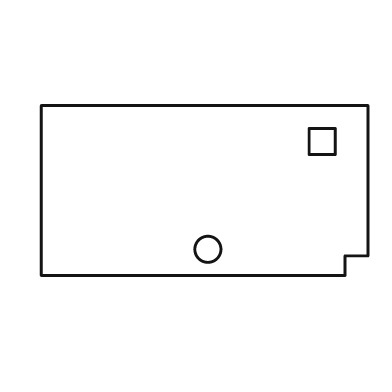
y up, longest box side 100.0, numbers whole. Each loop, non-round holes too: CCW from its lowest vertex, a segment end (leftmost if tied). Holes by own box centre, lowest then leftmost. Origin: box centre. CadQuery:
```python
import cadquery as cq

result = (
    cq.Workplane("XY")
    .moveTo(-50.0, -26.0)
    .lineTo(43.0, -26.0)
    .lineTo(43.0, -20.0)
    .lineTo(50.0, -20.0)
    .lineTo(50.0, 26.0)
    .lineTo(-50.0, 26.0)
    .close()
    .moveTo(1.0, -18.0)
    .circle(4.0)
    .moveTo(32.0, 11.0)
    .lineTo(40.0, 11.0)
    .lineTo(40.0, 19.0)
    .lineTo(32.0, 19.0)
    .close()
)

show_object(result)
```